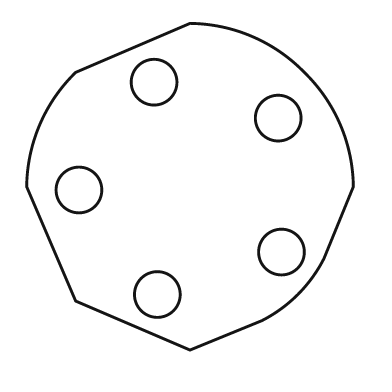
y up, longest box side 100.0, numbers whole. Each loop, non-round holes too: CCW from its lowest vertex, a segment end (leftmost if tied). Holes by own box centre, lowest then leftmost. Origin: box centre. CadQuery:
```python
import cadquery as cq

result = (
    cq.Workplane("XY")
    .moveTo(0.0, -50.0)
    .lineTo(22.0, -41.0)
    .threePointArc((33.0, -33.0), (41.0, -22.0))
    .lineTo(50.0, 0.0)
    .threePointArc((46.0, 19.0), (35.0, 35.0))
    .threePointArc((19.0, 46.0), (0.0, 50.0))
    .lineTo(-35.0, 35.0)
    .threePointArc((-46.0, 19.0), (-50.0, 0.0))
    .lineTo(-35.0, -35.0)
    .close()
    .moveTo(-10.0, -33.0)
    .circle(7.0)
    .moveTo(28.0, -20.0)
    .circle(7.0)
    .moveTo(-34.0, -1.0)
    .circle(7.0)
    .moveTo(27.0, 21.0)
    .circle(7.0)
    .moveTo(-11.0, 32.0)
    .circle(7.0)
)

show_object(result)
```